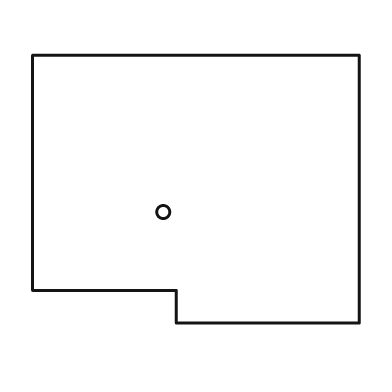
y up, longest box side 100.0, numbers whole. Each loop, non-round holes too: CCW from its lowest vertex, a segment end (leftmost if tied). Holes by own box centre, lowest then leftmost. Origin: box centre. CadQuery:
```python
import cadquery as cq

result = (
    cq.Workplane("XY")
    .moveTo(-6.0, -41.0)
    .lineTo(50.0, -41.0)
    .lineTo(50.0, 41.0)
    .lineTo(-50.0, 41.0)
    .lineTo(-50.0, -31.0)
    .lineTo(-6.0, -31.0)
    .close()
    .moveTo(-10.0, -7.0)
    .circle(2.0)
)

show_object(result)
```